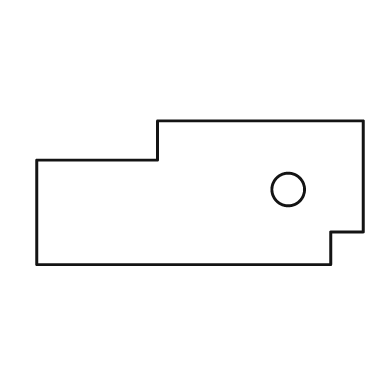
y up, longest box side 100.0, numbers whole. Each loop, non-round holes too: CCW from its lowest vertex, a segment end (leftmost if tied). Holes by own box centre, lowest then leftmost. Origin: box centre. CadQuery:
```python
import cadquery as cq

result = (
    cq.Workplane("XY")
    .moveTo(-50.0, -22.0)
    .lineTo(40.0, -22.0)
    .lineTo(40.0, -12.0)
    .lineTo(50.0, -12.0)
    .lineTo(50.0, 22.0)
    .lineTo(-13.0, 22.0)
    .lineTo(-13.0, 10.0)
    .lineTo(-50.0, 10.0)
    .close()
    .moveTo(27.0, 1.0)
    .circle(5.0)
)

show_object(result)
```